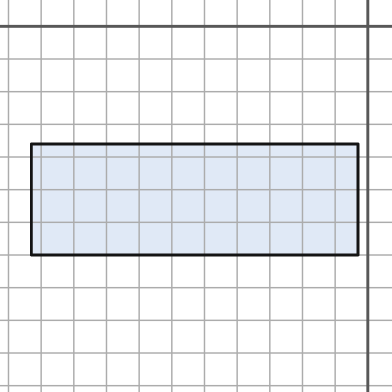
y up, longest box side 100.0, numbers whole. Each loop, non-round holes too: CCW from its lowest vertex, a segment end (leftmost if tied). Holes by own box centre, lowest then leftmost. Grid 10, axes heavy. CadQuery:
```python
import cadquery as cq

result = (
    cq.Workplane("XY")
    .moveTo(-103.0, -70.0)
    .lineTo(-3.0, -70.0)
    .lineTo(-3.0, -36.0)
    .lineTo(-103.0, -36.0)
    .close()
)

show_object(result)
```